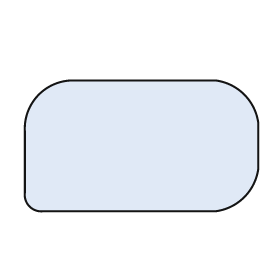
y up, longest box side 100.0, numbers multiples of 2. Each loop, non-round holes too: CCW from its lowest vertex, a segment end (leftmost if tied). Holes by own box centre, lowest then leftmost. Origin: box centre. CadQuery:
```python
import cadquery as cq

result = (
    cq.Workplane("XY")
    .moveTo(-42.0, -28.0)
    .lineTo(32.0, -28.0)
    .threePointArc((44.0, -22.0), (50.0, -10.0))
    .lineTo(50.0, 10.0)
    .threePointArc((44.0, 22.0), (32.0, 28.0))
    .lineTo(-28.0, 28.0)
    .threePointArc((-44.0, 22.0), (-50.0, 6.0))
    .lineTo(-50.0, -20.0)
    .threePointArc((-48.0, -26.0), (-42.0, -28.0))
    .close()
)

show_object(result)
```